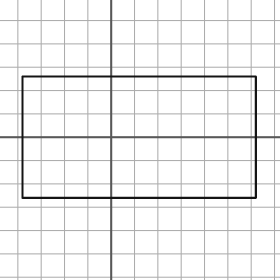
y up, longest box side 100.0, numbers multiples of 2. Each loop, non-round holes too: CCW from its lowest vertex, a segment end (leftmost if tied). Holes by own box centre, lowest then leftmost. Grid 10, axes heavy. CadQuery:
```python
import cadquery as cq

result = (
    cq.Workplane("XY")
    .moveTo(-38.0, -26.0)
    .lineTo(62.0, -26.0)
    .lineTo(62.0, 26.0)
    .lineTo(-38.0, 26.0)
    .close()
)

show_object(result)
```